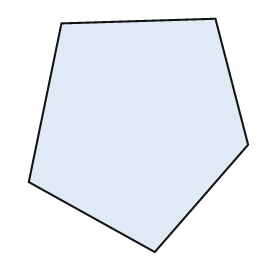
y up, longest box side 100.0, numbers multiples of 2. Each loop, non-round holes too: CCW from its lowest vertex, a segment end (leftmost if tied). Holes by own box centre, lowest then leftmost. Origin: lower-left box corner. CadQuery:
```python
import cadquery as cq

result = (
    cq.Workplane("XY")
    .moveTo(54.0, 0.0)
    .lineTo(94.0, 46.0)
    .lineTo(80.0, 100.0)
    .lineTo(14.0, 98.0)
    .lineTo(0.0, 30.0)
    .close()
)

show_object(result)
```